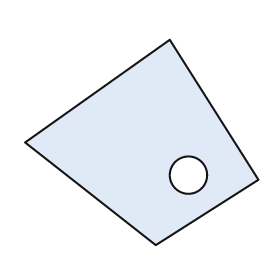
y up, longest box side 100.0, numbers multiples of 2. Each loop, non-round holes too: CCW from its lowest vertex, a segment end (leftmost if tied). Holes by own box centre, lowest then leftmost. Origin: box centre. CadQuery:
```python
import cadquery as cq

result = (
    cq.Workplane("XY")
    .moveTo(6.0, -44.0)
    .lineTo(50.0, -16.0)
    .lineTo(12.0, 44.0)
    .lineTo(-50.0, 0.0)
    .close()
    .moveTo(20.0, -14.0)
    .circle(8.0)
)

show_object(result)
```